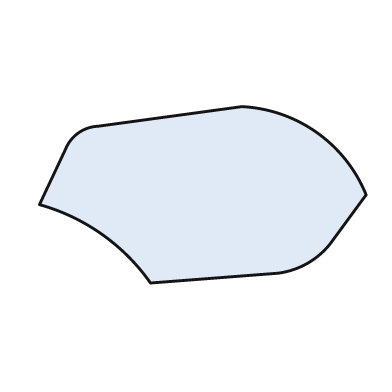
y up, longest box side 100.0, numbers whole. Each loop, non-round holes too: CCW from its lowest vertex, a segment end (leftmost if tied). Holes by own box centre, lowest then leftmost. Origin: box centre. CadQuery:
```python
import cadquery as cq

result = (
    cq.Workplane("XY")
    .moveTo(-16.0, -27.0)
    .lineTo(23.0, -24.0)
    .threePointArc((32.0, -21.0), (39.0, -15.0))
    .lineTo(50.0, 0.0)
    .threePointArc((35.0, 19.0), (12.0, 27.0))
    .lineTo(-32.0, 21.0)
    .threePointArc((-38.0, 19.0), (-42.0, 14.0))
    .lineTo(-50.0, -3.0)
    .threePointArc((-31.0, -12.0), (-16.0, -27.0))
    .close()
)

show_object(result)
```